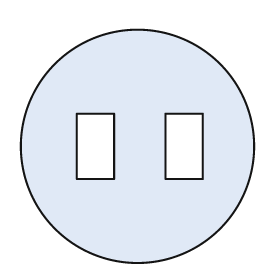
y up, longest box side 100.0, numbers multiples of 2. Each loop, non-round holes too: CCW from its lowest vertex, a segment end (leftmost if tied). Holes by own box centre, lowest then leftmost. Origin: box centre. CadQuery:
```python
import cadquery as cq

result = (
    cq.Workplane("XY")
    .moveTo(0.0, 0.0)
    .circle(50.0)
    .moveTo(-26.0, -14.0)
    .lineTo(-10.0, -14.0)
    .lineTo(-10.0, 14.0)
    .lineTo(-26.0, 14.0)
    .close()
    .moveTo(12.0, -14.0)
    .lineTo(28.0, -14.0)
    .lineTo(28.0, 14.0)
    .lineTo(12.0, 14.0)
    .close()
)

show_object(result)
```